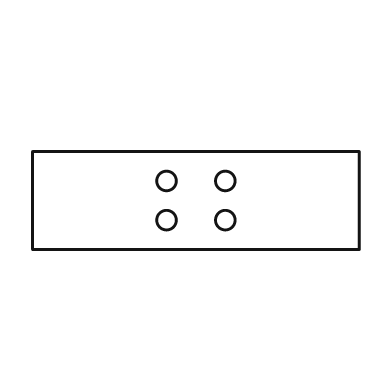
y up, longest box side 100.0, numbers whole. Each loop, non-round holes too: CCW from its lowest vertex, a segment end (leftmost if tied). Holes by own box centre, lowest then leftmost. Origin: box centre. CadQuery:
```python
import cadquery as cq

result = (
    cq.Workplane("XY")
    .moveTo(-50.0, -15.0)
    .lineTo(50.0, -15.0)
    .lineTo(50.0, 15.0)
    .lineTo(-50.0, 15.0)
    .close()
    .moveTo(-9.0, -6.0)
    .circle(3.0)
    .moveTo(9.0, -6.0)
    .circle(3.0)
    .moveTo(-9.0, 6.0)
    .circle(3.0)
    .moveTo(9.0, 6.0)
    .circle(3.0)
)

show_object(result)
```